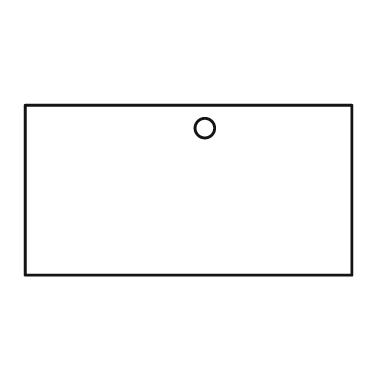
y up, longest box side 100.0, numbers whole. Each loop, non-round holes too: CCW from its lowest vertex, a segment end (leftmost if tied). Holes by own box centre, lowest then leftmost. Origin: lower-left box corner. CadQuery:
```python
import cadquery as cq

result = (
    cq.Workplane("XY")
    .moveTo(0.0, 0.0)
    .lineTo(100.0, 0.0)
    .lineTo(100.0, 52.0)
    .lineTo(0.0, 52.0)
    .close()
    .moveTo(55.0, 45.0)
    .circle(3.0)
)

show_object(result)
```